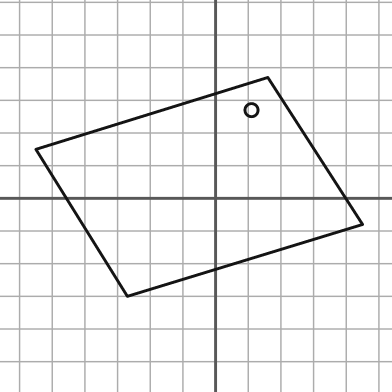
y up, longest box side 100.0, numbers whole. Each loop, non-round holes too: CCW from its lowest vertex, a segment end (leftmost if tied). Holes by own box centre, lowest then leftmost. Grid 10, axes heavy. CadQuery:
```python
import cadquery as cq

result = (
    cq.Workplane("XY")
    .moveTo(-27.0, -30.0)
    .lineTo(45.0, -8.0)
    .lineTo(16.0, 37.0)
    .lineTo(-55.0, 15.0)
    .close()
    .moveTo(11.0, 27.0)
    .circle(2.0)
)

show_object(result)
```